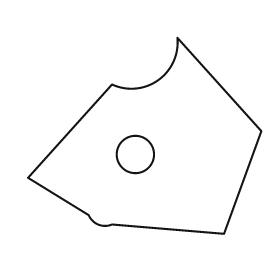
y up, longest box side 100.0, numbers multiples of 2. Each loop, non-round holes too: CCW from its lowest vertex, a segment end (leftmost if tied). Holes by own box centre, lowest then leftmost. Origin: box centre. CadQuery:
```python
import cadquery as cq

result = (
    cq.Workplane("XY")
    .moveTo(34.0, -42.0)
    .lineTo(50.0, 2.0)
    .lineTo(14.0, 42.0)
    .threePointArc((6.0, 24.0), (-14.0, 22.0))
    .lineTo(-50.0, -18.0)
    .lineTo(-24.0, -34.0)
    .threePointArc((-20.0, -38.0), (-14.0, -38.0))
    .close()
    .moveTo(-4.0, -8.0)
    .circle(8.0)
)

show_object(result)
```